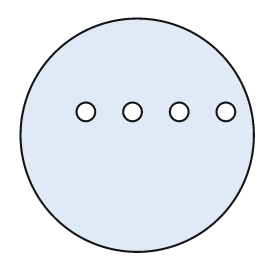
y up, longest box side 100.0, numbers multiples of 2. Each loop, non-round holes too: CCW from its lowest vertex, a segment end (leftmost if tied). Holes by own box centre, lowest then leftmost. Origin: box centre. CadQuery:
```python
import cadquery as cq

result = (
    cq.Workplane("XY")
    .moveTo(0.0, 0.0)
    .circle(50.0)
    .moveTo(-22.0, 10.0)
    .circle(4.0)
    .moveTo(-2.0, 10.0)
    .circle(4.0)
    .moveTo(18.0, 10.0)
    .circle(4.0)
    .moveTo(38.0, 10.0)
    .circle(4.0)
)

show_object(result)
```